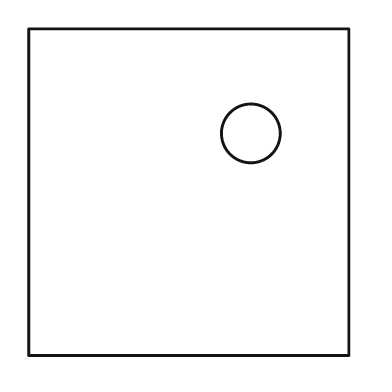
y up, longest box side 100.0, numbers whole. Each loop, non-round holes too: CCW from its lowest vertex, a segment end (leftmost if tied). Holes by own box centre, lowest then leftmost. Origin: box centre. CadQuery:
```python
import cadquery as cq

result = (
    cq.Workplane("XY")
    .moveTo(-49.0, -50.0)
    .lineTo(49.0, -50.0)
    .lineTo(49.0, 50.0)
    .lineTo(-49.0, 50.0)
    .close()
    .moveTo(19.0, 18.0)
    .circle(9.0)
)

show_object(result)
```